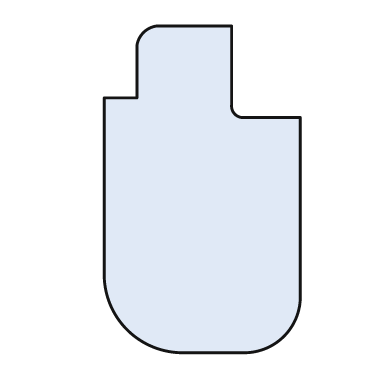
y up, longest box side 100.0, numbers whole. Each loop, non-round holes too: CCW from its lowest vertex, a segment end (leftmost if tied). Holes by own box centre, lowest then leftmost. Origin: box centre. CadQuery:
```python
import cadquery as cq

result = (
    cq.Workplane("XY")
    .moveTo(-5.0, -50.0)
    .lineTo(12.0, -50.0)
    .threePointArc((25.0, -45.0), (30.0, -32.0))
    .lineTo(30.0, 22.0)
    .lineTo(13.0, 22.0)
    .threePointArc((10.0, 23.0), (9.0, 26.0))
    .lineTo(9.0, 50.0)
    .lineTo(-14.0, 50.0)
    .threePointArc((-18.0, 48.0), (-20.0, 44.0))
    .lineTo(-20.0, 28.0)
    .lineTo(-30.0, 28.0)
    .lineTo(-30.0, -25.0)
    .threePointArc((-23.0, -43.0), (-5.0, -50.0))
    .close()
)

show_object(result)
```